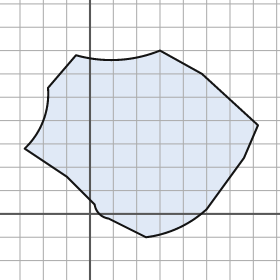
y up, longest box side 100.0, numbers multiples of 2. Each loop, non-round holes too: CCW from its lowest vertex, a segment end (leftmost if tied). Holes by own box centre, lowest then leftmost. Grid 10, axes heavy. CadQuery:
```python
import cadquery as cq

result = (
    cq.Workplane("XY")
    .moveTo(24.0, -10.0)
    .threePointArc((38.0, -6.0), (50.0, 2.0))
    .lineTo(66.0, 24.0)
    .lineTo(72.0, 38.0)
    .lineTo(48.0, 60.0)
    .lineTo(30.0, 70.0)
    .threePointArc((12.0, 66.0), (-6.0, 68.0))
    .lineTo(-18.0, 54.0)
    .threePointArc((-20.0, 40.0), (-28.0, 28.0))
    .lineTo(-10.0, 16.0)
    .lineTo(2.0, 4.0)
    .threePointArc((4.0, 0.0), (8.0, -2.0))
    .close()
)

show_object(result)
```